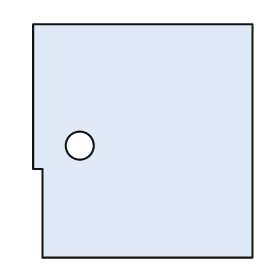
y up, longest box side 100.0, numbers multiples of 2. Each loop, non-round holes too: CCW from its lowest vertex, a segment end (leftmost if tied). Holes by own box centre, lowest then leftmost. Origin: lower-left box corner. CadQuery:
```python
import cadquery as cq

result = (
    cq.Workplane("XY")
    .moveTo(4.0, 0.0)
    .lineTo(94.0, 0.0)
    .lineTo(94.0, 100.0)
    .lineTo(0.0, 100.0)
    .lineTo(0.0, 38.0)
    .lineTo(4.0, 38.0)
    .close()
    .moveTo(20.0, 48.0)
    .circle(6.0)
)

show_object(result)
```